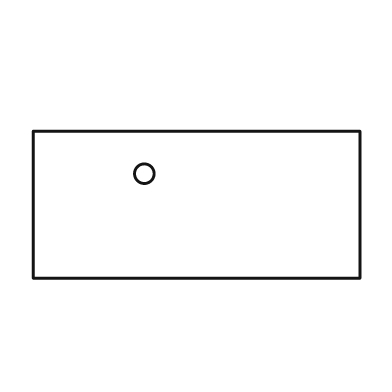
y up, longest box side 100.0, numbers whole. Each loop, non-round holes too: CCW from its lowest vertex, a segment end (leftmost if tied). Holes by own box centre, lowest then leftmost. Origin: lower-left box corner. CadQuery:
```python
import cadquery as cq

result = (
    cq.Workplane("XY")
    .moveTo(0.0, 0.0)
    .lineTo(100.0, 0.0)
    .lineTo(100.0, 45.0)
    .lineTo(0.0, 45.0)
    .close()
    .moveTo(34.0, 32.0)
    .circle(3.0)
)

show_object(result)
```